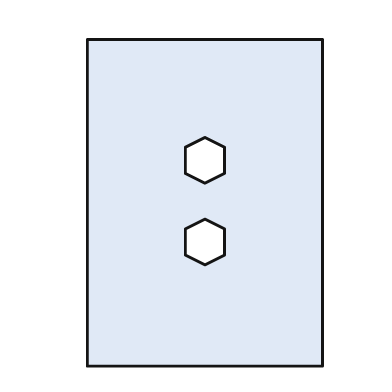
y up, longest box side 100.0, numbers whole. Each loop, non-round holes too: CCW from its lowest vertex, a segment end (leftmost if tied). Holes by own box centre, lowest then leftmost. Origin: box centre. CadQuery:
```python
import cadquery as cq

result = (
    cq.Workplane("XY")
    .moveTo(-36.0, -50.0)
    .lineTo(36.0, -50.0)
    .lineTo(36.0, 50.0)
    .lineTo(-36.0, 50.0)
    .close()
    .moveTo(0.0, -19.0)
    .lineTo(6.0, -16.0)
    .lineTo(6.0, -8.0)
    .lineTo(0.0, -5.0)
    .lineTo(-6.0, -8.0)
    .lineTo(-6.0, -16.0)
    .close()
    .moveTo(0.0, 6.0)
    .lineTo(6.0, 9.0)
    .lineTo(6.0, 17.0)
    .lineTo(0.0, 20.0)
    .lineTo(-6.0, 17.0)
    .lineTo(-6.0, 9.0)
    .close()
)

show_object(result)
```